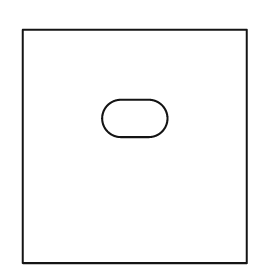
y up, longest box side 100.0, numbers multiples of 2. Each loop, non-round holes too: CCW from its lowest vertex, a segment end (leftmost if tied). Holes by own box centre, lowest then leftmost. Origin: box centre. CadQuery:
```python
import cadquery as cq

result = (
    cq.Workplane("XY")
    .moveTo(-48.0, -50.0)
    .lineTo(48.0, -50.0)
    .lineTo(48.0, 50.0)
    .lineTo(-48.0, 50.0)
    .close()
    .moveTo(-6.0, 4.0)
    .lineTo(6.0, 4.0)
    .threePointArc((14.0, 12.0), (6.0, 20.0))
    .lineTo(-6.0, 20.0)
    .threePointArc((-14.0, 12.0), (-6.0, 4.0))
    .close()
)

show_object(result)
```